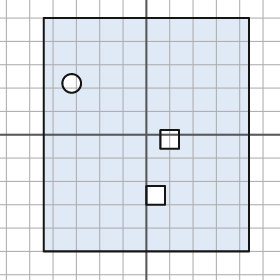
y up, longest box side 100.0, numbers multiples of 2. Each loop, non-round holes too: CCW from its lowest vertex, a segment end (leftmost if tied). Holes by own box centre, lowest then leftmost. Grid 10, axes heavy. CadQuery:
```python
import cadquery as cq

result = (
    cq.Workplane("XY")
    .moveTo(-44.0, -50.0)
    .lineTo(44.0, -50.0)
    .lineTo(44.0, 50.0)
    .lineTo(-44.0, 50.0)
    .close()
    .moveTo(0.0, -30.0)
    .lineTo(8.0, -30.0)
    .lineTo(8.0, -22.0)
    .lineTo(0.0, -22.0)
    .close()
    .moveTo(6.0, -6.0)
    .lineTo(14.0, -6.0)
    .lineTo(14.0, 2.0)
    .lineTo(6.0, 2.0)
    .close()
    .moveTo(-32.0, 22.0)
    .circle(4.0)
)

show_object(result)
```